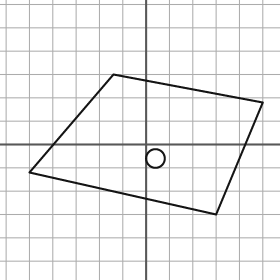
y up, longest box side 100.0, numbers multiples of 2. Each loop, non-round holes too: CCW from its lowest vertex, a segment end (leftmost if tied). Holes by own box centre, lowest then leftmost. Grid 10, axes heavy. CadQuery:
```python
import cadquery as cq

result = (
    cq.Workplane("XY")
    .moveTo(30.0, -30.0)
    .lineTo(50.0, 18.0)
    .lineTo(-14.0, 30.0)
    .lineTo(-50.0, -12.0)
    .close()
    .moveTo(4.0, -6.0)
    .circle(4.0)
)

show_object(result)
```